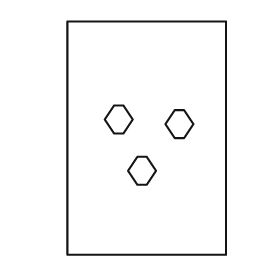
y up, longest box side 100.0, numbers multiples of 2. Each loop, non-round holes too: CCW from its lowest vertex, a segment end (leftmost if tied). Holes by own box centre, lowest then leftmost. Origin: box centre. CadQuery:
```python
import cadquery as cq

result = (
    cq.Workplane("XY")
    .moveTo(-34.0, -50.0)
    .lineTo(34.0, -50.0)
    .lineTo(34.0, 50.0)
    .lineTo(-34.0, 50.0)
    .close()
    .moveTo(-4.0, -20.0)
    .lineTo(0.0, -20.0)
    .lineTo(4.0, -14.0)
    .lineTo(0.0, -8.0)
    .lineTo(-4.0, -8.0)
    .lineTo(-8.0, -14.0)
    .close()
    .moveTo(12.0, 0.0)
    .lineTo(16.0, 0.0)
    .lineTo(20.0, 6.0)
    .lineTo(16.0, 12.0)
    .lineTo(12.0, 12.0)
    .lineTo(8.0, 6.0)
    .close()
    .moveTo(-14.0, 2.0)
    .lineTo(-10.0, 2.0)
    .lineTo(-6.0, 8.0)
    .lineTo(-10.0, 14.0)
    .lineTo(-14.0, 14.0)
    .lineTo(-18.0, 8.0)
    .close()
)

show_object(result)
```